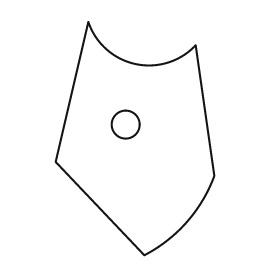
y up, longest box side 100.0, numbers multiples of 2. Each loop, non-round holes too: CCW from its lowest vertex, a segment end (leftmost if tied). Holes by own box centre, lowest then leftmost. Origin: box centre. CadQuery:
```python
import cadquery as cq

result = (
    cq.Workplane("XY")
    .moveTo(4.0, -50.0)
    .threePointArc((22.0, -36.0), (34.0, -16.0))
    .lineTo(26.0, 40.0)
    .threePointArc((0.0, 32.0), (-20.0, 50.0))
    .lineTo(-34.0, -10.0)
    .close()
    .moveTo(-4.0, 6.0)
    .circle(6.0)
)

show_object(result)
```